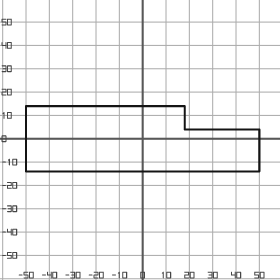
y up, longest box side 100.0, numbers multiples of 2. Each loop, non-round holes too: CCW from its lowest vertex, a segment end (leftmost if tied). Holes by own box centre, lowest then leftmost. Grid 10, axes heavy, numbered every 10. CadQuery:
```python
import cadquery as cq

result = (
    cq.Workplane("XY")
    .moveTo(-50.0, -14.0)
    .lineTo(50.0, -14.0)
    .lineTo(50.0, 4.0)
    .lineTo(18.0, 4.0)
    .lineTo(18.0, 14.0)
    .lineTo(-50.0, 14.0)
    .close()
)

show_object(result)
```